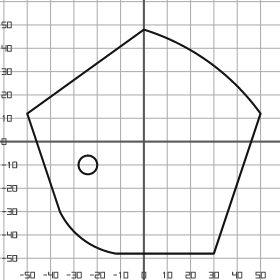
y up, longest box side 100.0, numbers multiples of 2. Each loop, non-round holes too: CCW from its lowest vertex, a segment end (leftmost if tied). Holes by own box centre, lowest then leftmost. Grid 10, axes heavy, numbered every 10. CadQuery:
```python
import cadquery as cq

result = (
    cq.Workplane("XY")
    .moveTo(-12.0, -48.0)
    .lineTo(30.0, -48.0)
    .lineTo(50.0, 12.0)
    .threePointArc((28.0, 34.0), (0.0, 48.0))
    .lineTo(-50.0, 12.0)
    .lineTo(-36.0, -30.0)
    .threePointArc((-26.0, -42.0), (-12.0, -48.0))
    .close()
    .moveTo(-24.0, -10.0)
    .circle(4.0)
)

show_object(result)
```